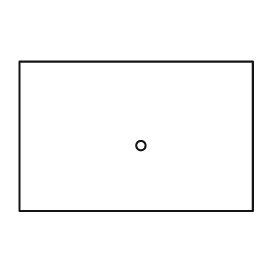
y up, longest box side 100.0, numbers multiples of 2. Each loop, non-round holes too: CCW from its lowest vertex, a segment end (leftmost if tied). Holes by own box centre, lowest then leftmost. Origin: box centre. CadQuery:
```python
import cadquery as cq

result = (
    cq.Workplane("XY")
    .moveTo(-50.0, -32.0)
    .lineTo(50.0, -32.0)
    .lineTo(50.0, 32.0)
    .lineTo(-50.0, 32.0)
    .close()
    .moveTo(2.0, -4.0)
    .circle(2.0)
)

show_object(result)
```